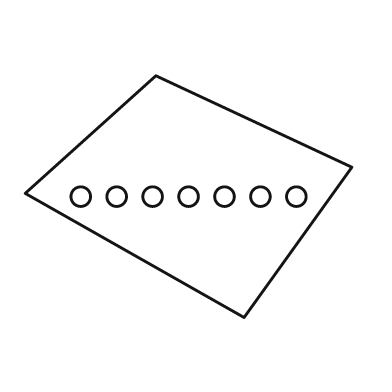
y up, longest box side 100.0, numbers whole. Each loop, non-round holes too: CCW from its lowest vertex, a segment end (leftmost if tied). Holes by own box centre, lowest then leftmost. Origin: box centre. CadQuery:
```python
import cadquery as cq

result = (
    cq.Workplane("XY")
    .moveTo(17.0, -37.0)
    .lineTo(50.0, 9.0)
    .lineTo(-10.0, 37.0)
    .lineTo(-50.0, 1.0)
    .close()
    .moveTo(-33.0, 0.0)
    .circle(3.0)
    .moveTo(-22.0, 0.0)
    .circle(3.0)
    .moveTo(-11.0, 0.0)
    .circle(3.0)
    .moveTo(0.0, 0.0)
    .circle(3.0)
    .moveTo(11.0, 0.0)
    .circle(3.0)
    .moveTo(22.0, 0.0)
    .circle(3.0)
    .moveTo(33.0, 0.0)
    .circle(3.0)
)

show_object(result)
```